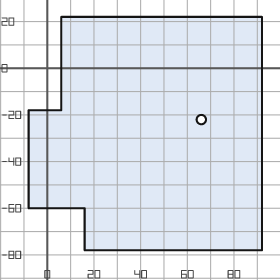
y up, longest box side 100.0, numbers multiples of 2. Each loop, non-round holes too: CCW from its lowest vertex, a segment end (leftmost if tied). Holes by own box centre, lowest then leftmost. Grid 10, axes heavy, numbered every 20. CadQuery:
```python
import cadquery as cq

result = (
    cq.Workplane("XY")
    .moveTo(16.0, -78.0)
    .lineTo(92.0, -78.0)
    .lineTo(92.0, 22.0)
    .lineTo(6.0, 22.0)
    .lineTo(6.0, -18.0)
    .lineTo(-8.0, -18.0)
    .lineTo(-8.0, -60.0)
    .lineTo(16.0, -60.0)
    .close()
    .moveTo(66.0, -22.0)
    .circle(2.0)
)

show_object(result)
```